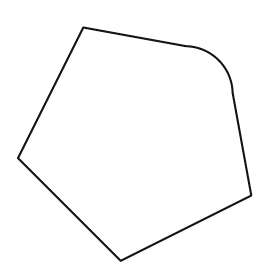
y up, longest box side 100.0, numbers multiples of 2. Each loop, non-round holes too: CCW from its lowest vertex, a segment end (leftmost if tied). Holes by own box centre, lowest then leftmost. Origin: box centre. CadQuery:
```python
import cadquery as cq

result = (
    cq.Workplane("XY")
    .moveTo(-6.0, -50.0)
    .lineTo(50.0, -22.0)
    .lineTo(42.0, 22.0)
    .threePointArc((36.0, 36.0), (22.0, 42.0))
    .lineTo(-22.0, 50.0)
    .lineTo(-50.0, -6.0)
    .close()
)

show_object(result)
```